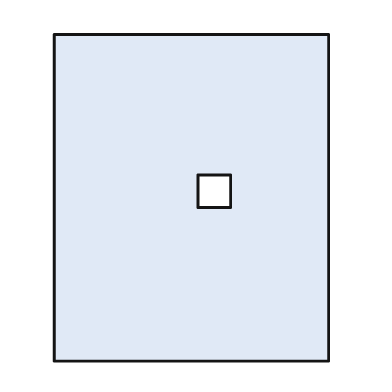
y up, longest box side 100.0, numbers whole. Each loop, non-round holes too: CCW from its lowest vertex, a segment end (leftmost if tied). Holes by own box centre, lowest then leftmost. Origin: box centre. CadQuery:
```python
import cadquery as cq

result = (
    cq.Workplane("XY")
    .moveTo(-42.0, -50.0)
    .lineTo(42.0, -50.0)
    .lineTo(42.0, 50.0)
    .lineTo(-42.0, 50.0)
    .close()
    .moveTo(2.0, -3.0)
    .lineTo(12.0, -3.0)
    .lineTo(12.0, 7.0)
    .lineTo(2.0, 7.0)
    .close()
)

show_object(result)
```